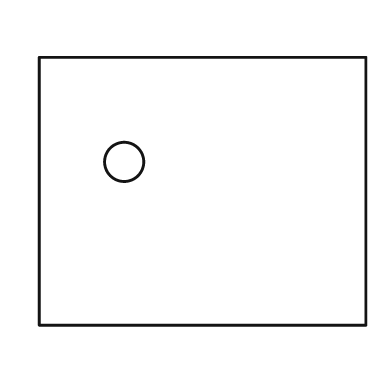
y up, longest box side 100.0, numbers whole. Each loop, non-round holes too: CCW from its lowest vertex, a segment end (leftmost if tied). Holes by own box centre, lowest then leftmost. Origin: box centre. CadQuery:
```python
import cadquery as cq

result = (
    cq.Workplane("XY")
    .moveTo(-50.0, -41.0)
    .lineTo(50.0, -41.0)
    .lineTo(50.0, 41.0)
    .lineTo(-50.0, 41.0)
    .close()
    .moveTo(-24.0, 9.0)
    .circle(6.0)
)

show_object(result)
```